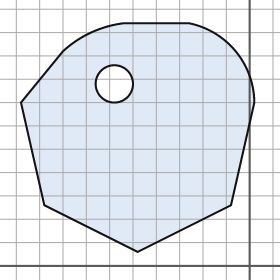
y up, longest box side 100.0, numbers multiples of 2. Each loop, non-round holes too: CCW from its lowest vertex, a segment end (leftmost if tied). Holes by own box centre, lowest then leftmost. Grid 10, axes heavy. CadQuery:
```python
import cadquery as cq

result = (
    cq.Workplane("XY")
    .moveTo(-48.0, 6.0)
    .lineTo(-8.0, 26.0)
    .lineTo(2.0, 70.0)
    .threePointArc((-6.0, 92.0), (-26.0, 104.0))
    .lineTo(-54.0, 104.0)
    .threePointArc((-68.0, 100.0), (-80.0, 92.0))
    .lineTo(-98.0, 70.0)
    .lineTo(-88.0, 26.0)
    .close()
    .moveTo(-58.0, 78.0)
    .circle(8.0)
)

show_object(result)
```